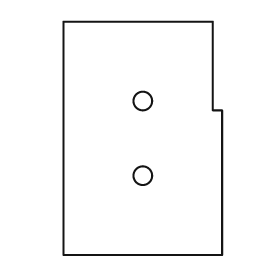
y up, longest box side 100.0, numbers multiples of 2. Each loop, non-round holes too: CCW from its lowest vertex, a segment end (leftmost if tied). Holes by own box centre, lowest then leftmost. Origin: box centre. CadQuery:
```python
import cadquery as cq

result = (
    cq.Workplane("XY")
    .moveTo(-34.0, -50.0)
    .lineTo(34.0, -50.0)
    .lineTo(34.0, 12.0)
    .lineTo(30.0, 12.0)
    .lineTo(30.0, 50.0)
    .lineTo(-34.0, 50.0)
    .close()
    .moveTo(0.0, -16.0)
    .circle(4.0)
    .moveTo(0.0, 16.0)
    .circle(4.0)
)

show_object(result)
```